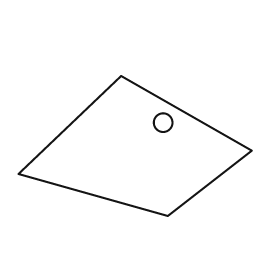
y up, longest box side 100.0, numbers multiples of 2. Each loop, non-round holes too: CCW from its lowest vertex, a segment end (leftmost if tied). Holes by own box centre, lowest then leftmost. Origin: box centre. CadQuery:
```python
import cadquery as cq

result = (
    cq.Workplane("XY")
    .moveTo(14.0, -30.0)
    .lineTo(50.0, -2.0)
    .lineTo(-6.0, 30.0)
    .lineTo(-50.0, -12.0)
    .close()
    .moveTo(12.0, 10.0)
    .circle(4.0)
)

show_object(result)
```